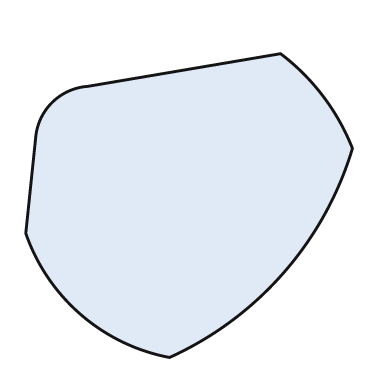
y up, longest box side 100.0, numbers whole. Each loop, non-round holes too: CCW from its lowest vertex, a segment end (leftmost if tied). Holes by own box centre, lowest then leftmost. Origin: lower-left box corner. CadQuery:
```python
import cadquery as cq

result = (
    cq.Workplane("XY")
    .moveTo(44.0, 0.0)
    .threePointArc((79.0, 26.0), (100.0, 64.0))
    .threePointArc((91.0, 80.0), (78.0, 93.0))
    .lineTo(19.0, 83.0)
    .threePointArc((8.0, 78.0), (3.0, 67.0))
    .lineTo(0.0, 38.0)
    .threePointArc((17.0, 13.0), (44.0, 0.0))
    .close()
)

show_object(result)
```